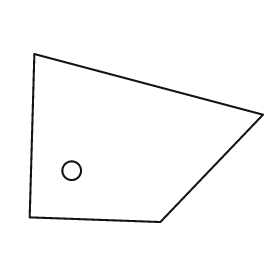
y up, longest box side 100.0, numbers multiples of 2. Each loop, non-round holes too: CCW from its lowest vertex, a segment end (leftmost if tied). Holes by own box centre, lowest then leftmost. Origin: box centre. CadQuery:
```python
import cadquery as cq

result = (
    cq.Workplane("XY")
    .moveTo(6.0, -36.0)
    .lineTo(50.0, 10.0)
    .lineTo(-48.0, 36.0)
    .lineTo(-50.0, -34.0)
    .close()
    .moveTo(-32.0, -14.0)
    .circle(4.0)
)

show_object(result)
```